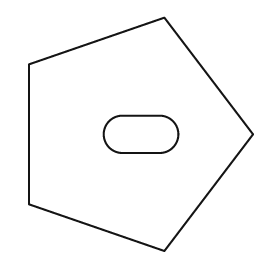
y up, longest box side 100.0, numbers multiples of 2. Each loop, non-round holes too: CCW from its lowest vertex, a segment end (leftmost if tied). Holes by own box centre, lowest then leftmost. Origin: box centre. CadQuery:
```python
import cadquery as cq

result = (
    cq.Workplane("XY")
    .moveTo(10.0, -50.0)
    .lineTo(48.0, 0.0)
    .lineTo(10.0, 50.0)
    .lineTo(-48.0, 30.0)
    .lineTo(-48.0, -30.0)
    .close()
    .moveTo(-8.0, -8.0)
    .lineTo(8.0, -8.0)
    .threePointArc((16.0, 0.0), (8.0, 8.0))
    .lineTo(-8.0, 8.0)
    .threePointArc((-16.0, 0.0), (-8.0, -8.0))
    .close()
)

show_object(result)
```